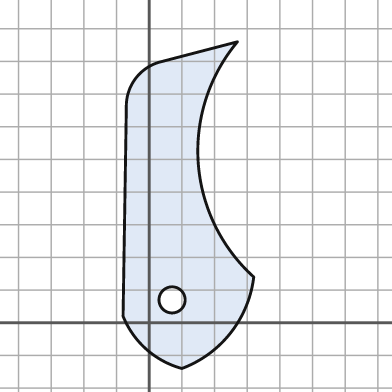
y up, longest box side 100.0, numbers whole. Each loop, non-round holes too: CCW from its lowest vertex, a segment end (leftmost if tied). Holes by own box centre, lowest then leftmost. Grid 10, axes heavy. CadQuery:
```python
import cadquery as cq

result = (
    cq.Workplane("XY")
    .moveTo(10.0, -14.0)
    .threePointArc((25.0, -3.0), (32.0, 14.0))
    .threePointArc((15.0, 49.0), (27.0, 86.0))
    .lineTo(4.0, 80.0)
    .threePointArc((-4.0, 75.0), (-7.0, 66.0))
    .lineTo(-8.0, 2.0)
    .threePointArc((-1.0, -8.0), (10.0, -14.0))
    .close()
    .moveTo(7.0, 7.0)
    .circle(4.0)
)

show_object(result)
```